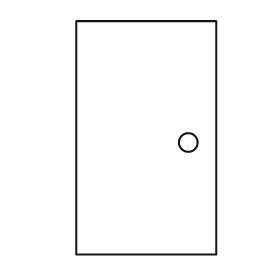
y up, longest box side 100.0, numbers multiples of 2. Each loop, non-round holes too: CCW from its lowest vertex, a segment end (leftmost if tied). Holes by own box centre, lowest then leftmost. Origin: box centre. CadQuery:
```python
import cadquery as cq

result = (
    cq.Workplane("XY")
    .moveTo(-30.0, -50.0)
    .lineTo(30.0, -50.0)
    .lineTo(30.0, 50.0)
    .lineTo(-30.0, 50.0)
    .close()
    .moveTo(18.0, -2.0)
    .circle(4.0)
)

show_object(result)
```